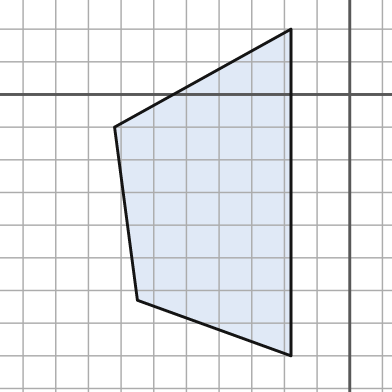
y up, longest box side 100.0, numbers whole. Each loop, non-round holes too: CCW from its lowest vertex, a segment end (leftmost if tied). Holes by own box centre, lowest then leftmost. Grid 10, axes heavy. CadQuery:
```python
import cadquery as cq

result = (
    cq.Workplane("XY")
    .moveTo(-18.0, -80.0)
    .lineTo(-18.0, 20.0)
    .lineTo(-72.0, -10.0)
    .lineTo(-65.0, -63.0)
    .close()
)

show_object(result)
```